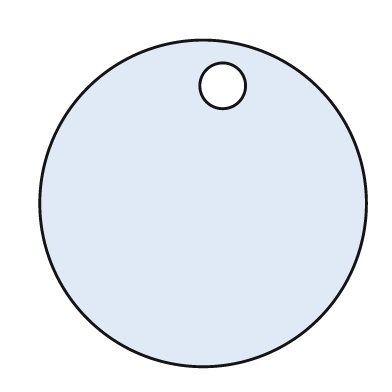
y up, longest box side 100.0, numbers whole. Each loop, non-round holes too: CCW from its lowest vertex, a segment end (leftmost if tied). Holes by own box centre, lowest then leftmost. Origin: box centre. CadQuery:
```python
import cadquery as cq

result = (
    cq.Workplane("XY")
    .moveTo(0.0, 0.0)
    .circle(50.0)
    .moveTo(6.0, 36.0)
    .circle(7.0)
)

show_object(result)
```